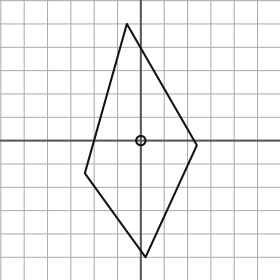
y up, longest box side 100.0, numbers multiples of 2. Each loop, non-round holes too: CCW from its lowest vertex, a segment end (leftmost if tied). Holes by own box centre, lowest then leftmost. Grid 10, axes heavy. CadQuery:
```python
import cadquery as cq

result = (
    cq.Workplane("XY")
    .moveTo(2.0, -50.0)
    .lineTo(24.0, -2.0)
    .lineTo(-6.0, 50.0)
    .lineTo(-24.0, -14.0)
    .close()
    .moveTo(0.0, 0.0)
    .circle(2.0)
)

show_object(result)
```